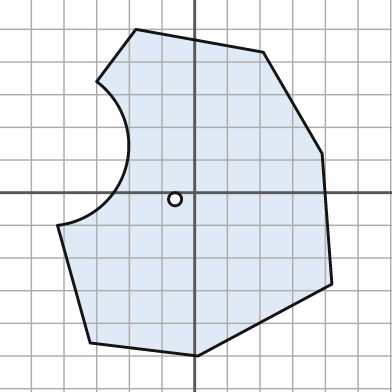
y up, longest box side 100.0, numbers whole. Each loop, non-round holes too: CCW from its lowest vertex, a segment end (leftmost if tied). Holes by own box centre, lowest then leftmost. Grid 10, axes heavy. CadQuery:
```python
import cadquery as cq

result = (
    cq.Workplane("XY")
    .moveTo(1.0, -50.0)
    .lineTo(42.0, -28.0)
    .lineTo(39.0, 12.0)
    .lineTo(21.0, 43.0)
    .lineTo(-18.0, 50.0)
    .lineTo(-30.0, 34.0)
    .threePointArc((-21.0, 8.0), (-42.0, -10.0))
    .lineTo(-32.0, -46.0)
    .close()
    .moveTo(-6.0, -2.0)
    .circle(2.0)
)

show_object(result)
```